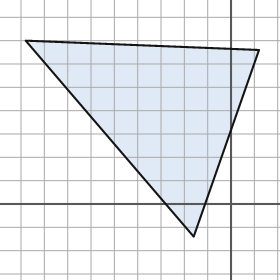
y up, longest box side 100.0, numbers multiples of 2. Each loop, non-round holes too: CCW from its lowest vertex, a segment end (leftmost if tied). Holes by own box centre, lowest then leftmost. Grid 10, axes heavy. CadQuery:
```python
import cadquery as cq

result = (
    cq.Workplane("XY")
    .moveTo(-16.0, -14.0)
    .lineTo(12.0, 66.0)
    .lineTo(-88.0, 70.0)
    .close()
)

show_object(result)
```